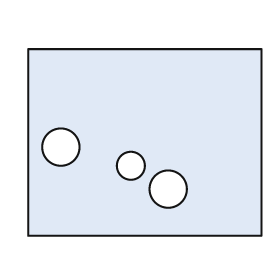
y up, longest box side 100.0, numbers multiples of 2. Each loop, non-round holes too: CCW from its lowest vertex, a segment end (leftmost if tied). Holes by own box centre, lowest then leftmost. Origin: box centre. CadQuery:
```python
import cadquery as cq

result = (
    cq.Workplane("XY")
    .moveTo(-50.0, -40.0)
    .lineTo(50.0, -40.0)
    .lineTo(50.0, 40.0)
    .lineTo(-50.0, 40.0)
    .close()
    .moveTo(10.0, -20.0)
    .circle(8.0)
    .moveTo(-6.0, -10.0)
    .circle(6.0)
    .moveTo(-36.0, -2.0)
    .circle(8.0)
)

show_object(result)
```